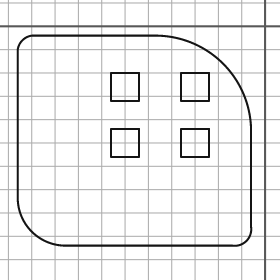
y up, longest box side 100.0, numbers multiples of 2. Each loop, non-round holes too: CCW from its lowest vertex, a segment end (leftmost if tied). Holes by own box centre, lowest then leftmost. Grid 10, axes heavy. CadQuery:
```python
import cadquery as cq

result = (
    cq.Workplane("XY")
    .moveTo(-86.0, -94.0)
    .lineTo(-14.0, -94.0)
    .threePointArc((-8.0, -92.0), (-6.0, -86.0))
    .lineTo(-6.0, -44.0)
    .threePointArc((-18.0, -16.0), (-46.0, -4.0))
    .lineTo(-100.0, -4.0)
    .threePointArc((-104.0, -6.0), (-106.0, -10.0))
    .lineTo(-106.0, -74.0)
    .threePointArc((-100.0, -88.0), (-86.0, -94.0))
    .close()
    .moveTo(-66.0, -56.0)
    .lineTo(-54.0, -56.0)
    .lineTo(-54.0, -44.0)
    .lineTo(-66.0, -44.0)
    .close()
    .moveTo(-36.0, -56.0)
    .lineTo(-24.0, -56.0)
    .lineTo(-24.0, -44.0)
    .lineTo(-36.0, -44.0)
    .close()
    .moveTo(-66.0, -32.0)
    .lineTo(-54.0, -32.0)
    .lineTo(-54.0, -20.0)
    .lineTo(-66.0, -20.0)
    .close()
    .moveTo(-36.0, -32.0)
    .lineTo(-24.0, -32.0)
    .lineTo(-24.0, -20.0)
    .lineTo(-36.0, -20.0)
    .close()
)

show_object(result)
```